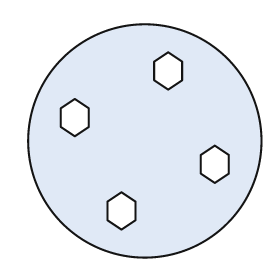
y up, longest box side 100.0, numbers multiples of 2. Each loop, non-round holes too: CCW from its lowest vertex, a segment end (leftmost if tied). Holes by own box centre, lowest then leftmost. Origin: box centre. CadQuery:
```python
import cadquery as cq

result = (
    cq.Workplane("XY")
    .moveTo(0.0, 0.0)
    .circle(50.0)
    .moveTo(-10.0, -38.0)
    .lineTo(-4.0, -34.0)
    .lineTo(-4.0, -26.0)
    .lineTo(-10.0, -22.0)
    .lineTo(-16.0, -26.0)
    .lineTo(-16.0, -34.0)
    .close()
    .moveTo(30.0, -18.0)
    .lineTo(36.0, -14.0)
    .lineTo(36.0, -6.0)
    .lineTo(30.0, -2.0)
    .lineTo(24.0, -6.0)
    .lineTo(24.0, -14.0)
    .close()
    .moveTo(-30.0, 2.0)
    .lineTo(-24.0, 6.0)
    .lineTo(-24.0, 14.0)
    .lineTo(-30.0, 18.0)
    .lineTo(-36.0, 14.0)
    .lineTo(-36.0, 6.0)
    .close()
    .moveTo(10.0, 22.0)
    .lineTo(16.0, 26.0)
    .lineTo(16.0, 34.0)
    .lineTo(10.0, 38.0)
    .lineTo(4.0, 34.0)
    .lineTo(4.0, 26.0)
    .close()
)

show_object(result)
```